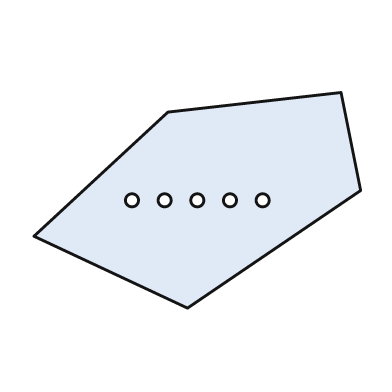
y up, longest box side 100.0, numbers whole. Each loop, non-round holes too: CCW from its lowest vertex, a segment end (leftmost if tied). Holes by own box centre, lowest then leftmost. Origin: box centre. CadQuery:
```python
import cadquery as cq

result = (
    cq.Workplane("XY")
    .moveTo(-3.0, -33.0)
    .lineTo(50.0, 3.0)
    .lineTo(44.0, 33.0)
    .lineTo(-9.0, 27.0)
    .lineTo(-50.0, -11.0)
    .close()
    .moveTo(-20.0, 0.0)
    .circle(2.0)
    .moveTo(-10.0, 0.0)
    .circle(2.0)
    .moveTo(0.0, 0.0)
    .circle(2.0)
    .moveTo(10.0, 0.0)
    .circle(2.0)
    .moveTo(20.0, 0.0)
    .circle(2.0)
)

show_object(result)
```